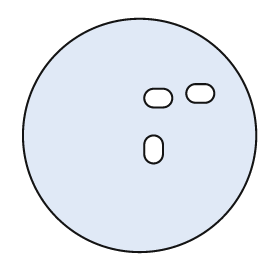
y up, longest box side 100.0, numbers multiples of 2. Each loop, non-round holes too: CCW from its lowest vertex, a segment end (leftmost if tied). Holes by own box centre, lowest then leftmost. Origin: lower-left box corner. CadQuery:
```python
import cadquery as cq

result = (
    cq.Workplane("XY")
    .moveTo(50.0, 50.0)
    .circle(50.0)
    .moveTo(52.0, 42.0)
    .threePointArc((56.0, 38.0), (60.0, 42.0))
    .lineTo(60.0, 46.0)
    .threePointArc((56.0, 50.0), (52.0, 46.0))
    .close()
    .moveTo(56.0, 62.0)
    .lineTo(60.0, 62.0)
    .threePointArc((64.0, 66.0), (60.0, 70.0))
    .lineTo(56.0, 70.0)
    .threePointArc((52.0, 66.0), (56.0, 62.0))
    .close()
    .moveTo(74.0, 64.0)
    .lineTo(78.0, 64.0)
    .threePointArc((82.0, 68.0), (78.0, 72.0))
    .lineTo(74.0, 72.0)
    .threePointArc((70.0, 68.0), (74.0, 64.0))
    .close()
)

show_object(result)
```